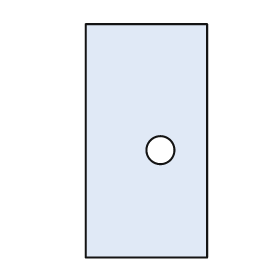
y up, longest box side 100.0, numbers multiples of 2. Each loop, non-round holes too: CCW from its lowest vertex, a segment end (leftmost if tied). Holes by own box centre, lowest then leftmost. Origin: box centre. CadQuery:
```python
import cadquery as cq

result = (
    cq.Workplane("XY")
    .moveTo(-26.0, -50.0)
    .lineTo(26.0, -50.0)
    .lineTo(26.0, 50.0)
    .lineTo(-26.0, 50.0)
    .close()
    .moveTo(6.0, -4.0)
    .circle(6.0)
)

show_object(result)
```